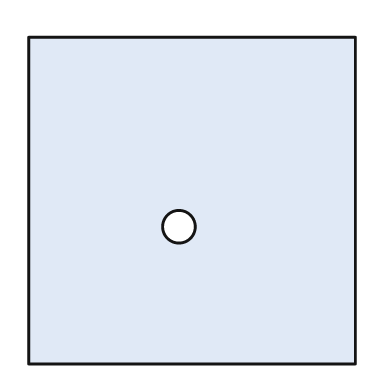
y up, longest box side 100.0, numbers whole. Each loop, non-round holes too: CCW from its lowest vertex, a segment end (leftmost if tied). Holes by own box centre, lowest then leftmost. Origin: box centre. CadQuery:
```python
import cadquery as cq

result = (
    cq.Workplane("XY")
    .moveTo(-50.0, -50.0)
    .lineTo(50.0, -50.0)
    .lineTo(50.0, 50.0)
    .lineTo(-50.0, 50.0)
    .close()
    .moveTo(-4.0, -8.0)
    .circle(5.0)
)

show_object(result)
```